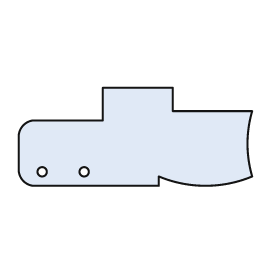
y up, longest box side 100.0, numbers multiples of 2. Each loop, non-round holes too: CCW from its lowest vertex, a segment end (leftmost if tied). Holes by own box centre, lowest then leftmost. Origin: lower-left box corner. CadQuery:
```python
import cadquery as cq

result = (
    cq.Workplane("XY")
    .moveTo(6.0, 0.0)
    .lineTo(60.0, 0.0)
    .lineTo(60.0, 4.0)
    .threePointArc((80.0, 0.0), (100.0, 4.0))
    .threePointArc((98.0, 18.0), (100.0, 32.0))
    .lineTo(66.0, 32.0)
    .lineTo(66.0, 42.0)
    .lineTo(36.0, 42.0)
    .lineTo(36.0, 28.0)
    .lineTo(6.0, 28.0)
    .threePointArc((2.0, 26.0), (0.0, 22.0))
    .lineTo(0.0, 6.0)
    .threePointArc((2.0, 2.0), (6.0, 0.0))
    .close()
    .moveTo(10.0, 6.0)
    .circle(2.0)
    .moveTo(28.0, 6.0)
    .circle(2.0)
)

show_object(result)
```